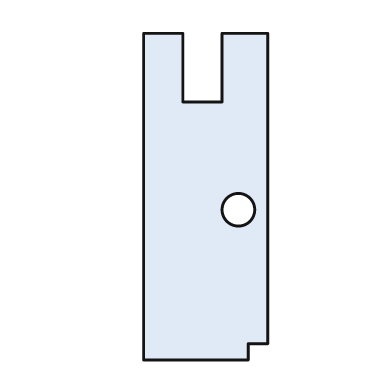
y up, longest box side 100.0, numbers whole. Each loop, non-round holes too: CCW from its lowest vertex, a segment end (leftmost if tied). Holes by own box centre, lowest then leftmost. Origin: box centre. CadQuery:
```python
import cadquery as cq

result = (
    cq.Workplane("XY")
    .moveTo(-19.0, -50.0)
    .lineTo(13.0, -50.0)
    .lineTo(13.0, -45.0)
    .lineTo(19.0, -45.0)
    .lineTo(19.0, 50.0)
    .lineTo(5.0, 50.0)
    .lineTo(5.0, 29.0)
    .lineTo(-7.0, 29.0)
    .lineTo(-7.0, 50.0)
    .lineTo(-19.0, 50.0)
    .close()
    .moveTo(10.0, -4.0)
    .circle(5.0)
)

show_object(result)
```